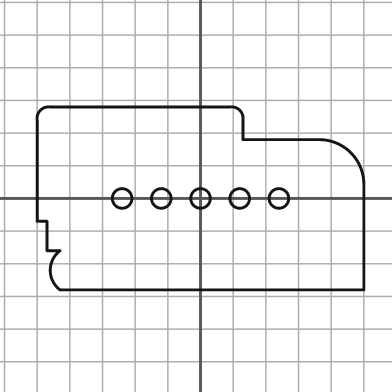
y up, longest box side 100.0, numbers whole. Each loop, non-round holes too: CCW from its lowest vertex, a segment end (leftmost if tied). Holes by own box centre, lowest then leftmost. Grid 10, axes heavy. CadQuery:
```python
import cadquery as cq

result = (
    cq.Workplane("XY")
    .moveTo(-43.0, -28.0)
    .lineTo(50.0, -28.0)
    .lineTo(50.0, 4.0)
    .threePointArc((46.0, 14.0), (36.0, 18.0))
    .lineTo(13.0, 18.0)
    .lineTo(13.0, 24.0)
    .threePointArc((12.0, 27.0), (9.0, 28.0))
    .lineTo(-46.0, 28.0)
    .threePointArc((-49.0, 27.0), (-50.0, 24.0))
    .lineTo(-50.0, -7.0)
    .lineTo(-47.0, -7.0)
    .lineTo(-47.0, -16.0)
    .lineTo(-43.0, -16.0)
    .threePointArc((-46.0, -22.0), (-43.0, -28.0))
    .close()
    .moveTo(-24.0, 0.0)
    .circle(3.0)
    .moveTo(-12.0, 0.0)
    .circle(3.0)
    .moveTo(0.0, 0.0)
    .circle(3.0)
    .moveTo(12.0, 0.0)
    .circle(3.0)
    .moveTo(24.0, 0.0)
    .circle(3.0)
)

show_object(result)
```